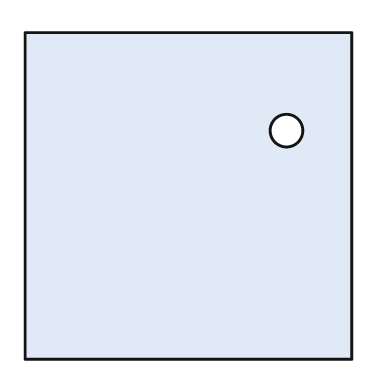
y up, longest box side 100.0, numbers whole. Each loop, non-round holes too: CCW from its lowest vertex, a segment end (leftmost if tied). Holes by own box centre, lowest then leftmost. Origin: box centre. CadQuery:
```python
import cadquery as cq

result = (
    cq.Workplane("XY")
    .moveTo(-50.0, -50.0)
    .lineTo(50.0, -50.0)
    .lineTo(50.0, 50.0)
    .lineTo(-50.0, 50.0)
    .close()
    .moveTo(30.0, 20.0)
    .circle(5.0)
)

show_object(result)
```